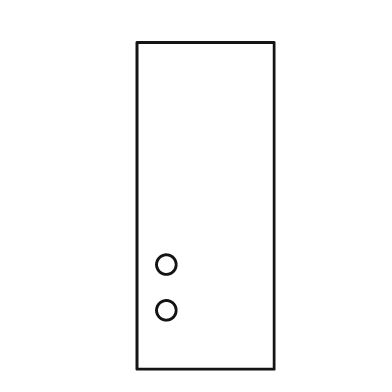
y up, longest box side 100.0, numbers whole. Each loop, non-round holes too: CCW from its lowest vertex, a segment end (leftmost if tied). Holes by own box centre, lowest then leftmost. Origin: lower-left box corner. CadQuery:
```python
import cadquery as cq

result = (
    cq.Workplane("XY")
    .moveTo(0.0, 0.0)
    .lineTo(42.0, 0.0)
    .lineTo(42.0, 100.0)
    .lineTo(0.0, 100.0)
    .close()
    .moveTo(9.0, 18.0)
    .circle(3.0)
    .moveTo(9.0, 32.0)
    .circle(3.0)
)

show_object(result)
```